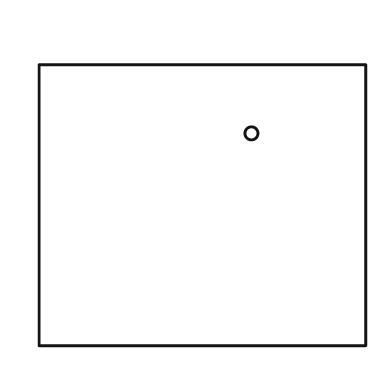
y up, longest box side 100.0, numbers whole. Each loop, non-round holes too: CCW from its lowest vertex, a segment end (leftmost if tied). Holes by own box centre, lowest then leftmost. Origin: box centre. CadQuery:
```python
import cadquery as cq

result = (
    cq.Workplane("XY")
    .moveTo(-50.0, -43.0)
    .lineTo(50.0, -43.0)
    .lineTo(50.0, 43.0)
    .lineTo(-50.0, 43.0)
    .close()
    .moveTo(15.0, 22.0)
    .circle(2.0)
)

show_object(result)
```